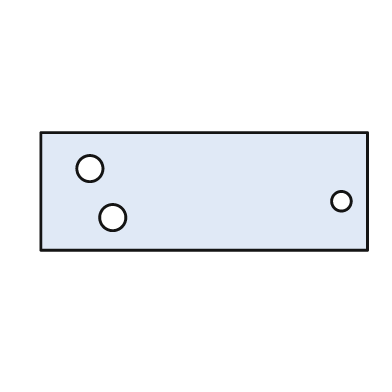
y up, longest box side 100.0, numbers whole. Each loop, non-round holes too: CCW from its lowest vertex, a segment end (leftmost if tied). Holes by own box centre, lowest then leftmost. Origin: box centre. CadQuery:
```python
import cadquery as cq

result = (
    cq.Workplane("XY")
    .moveTo(-50.0, -18.0)
    .lineTo(50.0, -18.0)
    .lineTo(50.0, 18.0)
    .lineTo(-50.0, 18.0)
    .close()
    .moveTo(-28.0, -8.0)
    .circle(4.0)
    .moveTo(42.0, -3.0)
    .circle(3.0)
    .moveTo(-35.0, 7.0)
    .circle(4.0)
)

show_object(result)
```